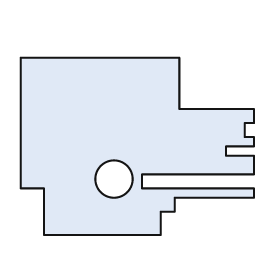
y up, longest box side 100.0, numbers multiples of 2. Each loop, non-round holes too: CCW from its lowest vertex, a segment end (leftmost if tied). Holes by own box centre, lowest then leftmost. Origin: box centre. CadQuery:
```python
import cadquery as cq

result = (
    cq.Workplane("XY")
    .moveTo(-40.0, -38.0)
    .lineTo(10.0, -38.0)
    .lineTo(10.0, -28.0)
    .lineTo(16.0, -28.0)
    .lineTo(16.0, -22.0)
    .lineTo(50.0, -22.0)
    .lineTo(50.0, -18.0)
    .lineTo(2.0, -18.0)
    .lineTo(2.0, -12.0)
    .lineTo(50.0, -12.0)
    .lineTo(50.0, -4.0)
    .lineTo(38.0, -4.0)
    .lineTo(38.0, 0.0)
    .lineTo(50.0, 0.0)
    .lineTo(50.0, 4.0)
    .lineTo(46.0, 4.0)
    .lineTo(46.0, 10.0)
    .lineTo(50.0, 10.0)
    .lineTo(50.0, 16.0)
    .lineTo(18.0, 16.0)
    .lineTo(18.0, 38.0)
    .lineTo(-50.0, 38.0)
    .lineTo(-50.0, -18.0)
    .lineTo(-40.0, -18.0)
    .close()
    .moveTo(-10.0, -14.0)
    .circle(8.0)
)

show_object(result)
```